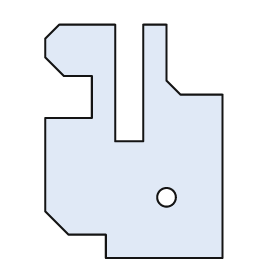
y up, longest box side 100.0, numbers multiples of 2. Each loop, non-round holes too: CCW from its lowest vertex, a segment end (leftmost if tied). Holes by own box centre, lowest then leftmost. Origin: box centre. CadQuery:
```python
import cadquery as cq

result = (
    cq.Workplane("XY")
    .moveTo(-12.0, -50.0)
    .lineTo(38.0, -50.0)
    .lineTo(38.0, 20.0)
    .lineTo(20.0, 20.0)
    .lineTo(14.0, 26.0)
    .lineTo(14.0, 50.0)
    .lineTo(4.0, 50.0)
    .lineTo(4.0, 0.0)
    .lineTo(-8.0, 0.0)
    .lineTo(-8.0, 50.0)
    .lineTo(-32.0, 50.0)
    .lineTo(-38.0, 44.0)
    .lineTo(-38.0, 36.0)
    .lineTo(-30.0, 28.0)
    .lineTo(-18.0, 28.0)
    .lineTo(-18.0, 10.0)
    .lineTo(-38.0, 10.0)
    .lineTo(-38.0, -30.0)
    .lineTo(-28.0, -40.0)
    .lineTo(-12.0, -40.0)
    .close()
    .moveTo(14.0, -24.0)
    .circle(4.0)
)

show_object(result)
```